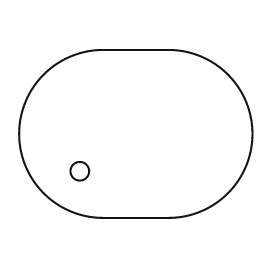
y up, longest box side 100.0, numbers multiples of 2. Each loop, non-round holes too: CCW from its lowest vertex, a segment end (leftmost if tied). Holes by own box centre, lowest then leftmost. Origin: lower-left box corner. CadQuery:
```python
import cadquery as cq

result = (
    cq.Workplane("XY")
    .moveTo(36.0, 0.0)
    .lineTo(64.0, 0.0)
    .threePointArc((100.0, 36.0), (64.0, 72.0))
    .lineTo(36.0, 72.0)
    .threePointArc((0.0, 36.0), (36.0, 0.0))
    .close()
    .moveTo(26.0, 20.0)
    .circle(4.0)
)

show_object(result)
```